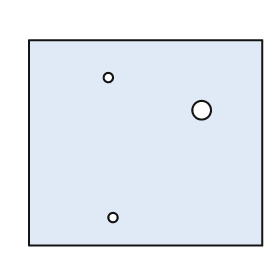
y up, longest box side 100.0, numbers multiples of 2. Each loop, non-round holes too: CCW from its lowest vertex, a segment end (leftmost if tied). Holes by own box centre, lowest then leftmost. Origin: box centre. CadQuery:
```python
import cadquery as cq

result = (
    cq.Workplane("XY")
    .moveTo(-50.0, -44.0)
    .lineTo(50.0, -44.0)
    .lineTo(50.0, 44.0)
    .lineTo(-50.0, 44.0)
    .close()
    .moveTo(-14.0, -32.0)
    .circle(2.0)
    .moveTo(24.0, 14.0)
    .circle(4.0)
    .moveTo(-16.0, 28.0)
    .circle(2.0)
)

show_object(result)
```